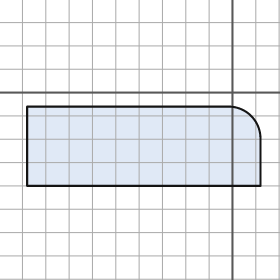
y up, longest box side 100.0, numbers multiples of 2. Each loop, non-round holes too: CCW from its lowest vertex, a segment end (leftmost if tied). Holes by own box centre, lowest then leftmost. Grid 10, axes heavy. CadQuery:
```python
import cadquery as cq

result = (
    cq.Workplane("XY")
    .moveTo(-88.0, -40.0)
    .lineTo(12.0, -40.0)
    .lineTo(12.0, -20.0)
    .threePointArc((8.0, -10.0), (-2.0, -6.0))
    .lineTo(-88.0, -6.0)
    .close()
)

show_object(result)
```